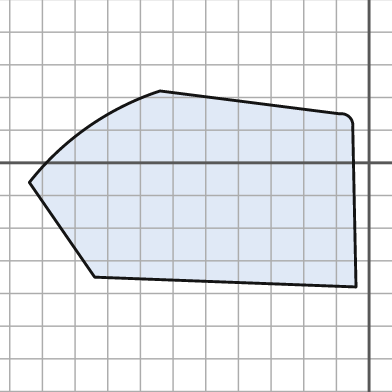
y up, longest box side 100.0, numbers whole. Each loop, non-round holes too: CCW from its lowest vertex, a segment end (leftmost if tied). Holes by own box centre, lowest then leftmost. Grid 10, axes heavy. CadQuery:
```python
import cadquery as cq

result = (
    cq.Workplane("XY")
    .moveTo(-4.0, -38.0)
    .lineTo(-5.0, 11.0)
    .threePointArc((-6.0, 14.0), (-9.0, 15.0))
    .lineTo(-64.0, 22.0)
    .threePointArc((-86.0, 11.0), (-104.0, -6.0))
    .lineTo(-84.0, -35.0)
    .close()
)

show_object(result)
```